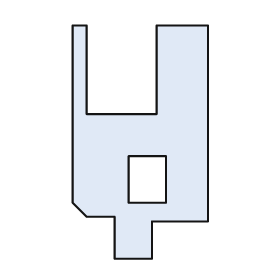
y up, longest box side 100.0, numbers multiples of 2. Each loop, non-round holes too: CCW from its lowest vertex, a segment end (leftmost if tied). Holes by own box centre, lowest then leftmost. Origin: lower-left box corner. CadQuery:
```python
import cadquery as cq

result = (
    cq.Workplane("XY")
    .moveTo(18.0, 0.0)
    .lineTo(34.0, 0.0)
    .lineTo(34.0, 16.0)
    .lineTo(58.0, 16.0)
    .lineTo(58.0, 100.0)
    .lineTo(36.0, 100.0)
    .lineTo(36.0, 62.0)
    .lineTo(6.0, 62.0)
    .lineTo(6.0, 100.0)
    .lineTo(0.0, 100.0)
    .lineTo(0.0, 24.0)
    .lineTo(6.0, 18.0)
    .lineTo(18.0, 18.0)
    .close()
    .moveTo(24.0, 24.0)
    .lineTo(40.0, 24.0)
    .lineTo(40.0, 44.0)
    .lineTo(24.0, 44.0)
    .close()
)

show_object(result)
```